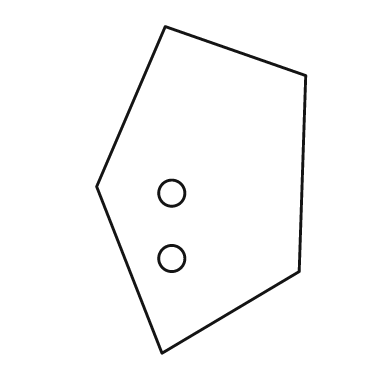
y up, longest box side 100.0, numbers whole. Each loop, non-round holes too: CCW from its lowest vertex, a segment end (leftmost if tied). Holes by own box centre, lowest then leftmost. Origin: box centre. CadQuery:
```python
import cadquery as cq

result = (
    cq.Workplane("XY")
    .moveTo(-12.0, -50.0)
    .lineTo(30.0, -25.0)
    .lineTo(32.0, 35.0)
    .lineTo(-11.0, 50.0)
    .lineTo(-32.0, 1.0)
    .close()
    .moveTo(-9.0, -21.0)
    .circle(4.0)
    .moveTo(-9.0, -1.0)
    .circle(4.0)
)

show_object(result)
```